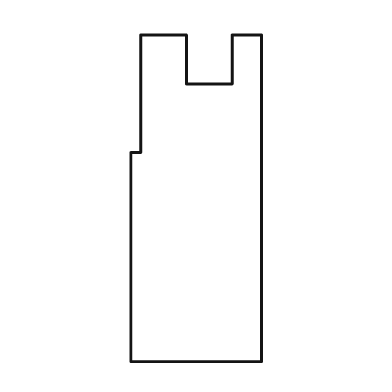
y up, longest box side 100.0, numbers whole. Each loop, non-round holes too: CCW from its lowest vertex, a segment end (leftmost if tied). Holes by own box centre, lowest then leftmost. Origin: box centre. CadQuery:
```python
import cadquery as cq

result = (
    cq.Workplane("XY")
    .moveTo(-20.0, -50.0)
    .lineTo(20.0, -50.0)
    .lineTo(20.0, 50.0)
    .lineTo(11.0, 50.0)
    .lineTo(11.0, 35.0)
    .lineTo(-3.0, 35.0)
    .lineTo(-3.0, 50.0)
    .lineTo(-17.0, 50.0)
    .lineTo(-17.0, 14.0)
    .lineTo(-20.0, 14.0)
    .close()
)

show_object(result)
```